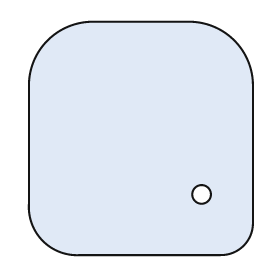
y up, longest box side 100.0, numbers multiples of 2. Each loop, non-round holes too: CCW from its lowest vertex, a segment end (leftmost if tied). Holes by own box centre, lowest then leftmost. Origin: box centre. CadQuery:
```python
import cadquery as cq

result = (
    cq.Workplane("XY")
    .moveTo(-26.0, -50.0)
    .lineTo(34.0, -50.0)
    .threePointArc((44.0, -46.0), (48.0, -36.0))
    .lineTo(48.0, 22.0)
    .threePointArc((40.0, 42.0), (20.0, 50.0))
    .lineTo(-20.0, 50.0)
    .threePointArc((-40.0, 42.0), (-48.0, 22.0))
    .lineTo(-48.0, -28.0)
    .threePointArc((-42.0, -44.0), (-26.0, -50.0))
    .close()
    .moveTo(26.0, -24.0)
    .circle(4.0)
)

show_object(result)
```